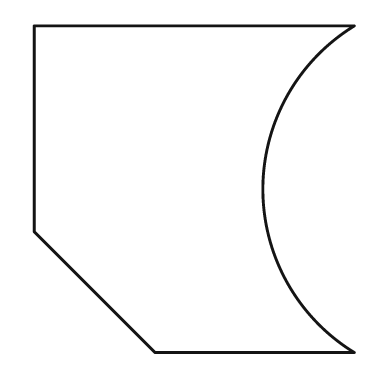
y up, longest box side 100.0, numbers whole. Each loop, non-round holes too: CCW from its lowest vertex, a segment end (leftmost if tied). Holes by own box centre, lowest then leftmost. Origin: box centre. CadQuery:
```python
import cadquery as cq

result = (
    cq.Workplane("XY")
    .moveTo(-12.0, -50.0)
    .lineTo(49.0, -50.0)
    .threePointArc((21.0, 0.0), (49.0, 50.0))
    .lineTo(-49.0, 50.0)
    .lineTo(-49.0, -13.0)
    .close()
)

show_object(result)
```